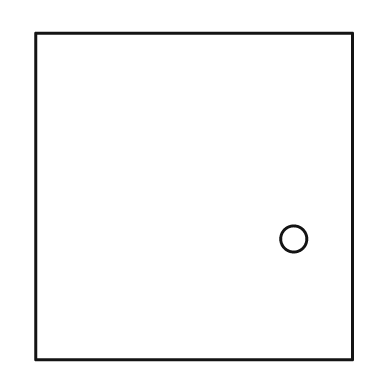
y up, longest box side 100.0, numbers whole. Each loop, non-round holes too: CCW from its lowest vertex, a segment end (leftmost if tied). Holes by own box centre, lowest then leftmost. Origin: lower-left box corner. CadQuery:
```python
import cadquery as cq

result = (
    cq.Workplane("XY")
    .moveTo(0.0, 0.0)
    .lineTo(97.0, 0.0)
    .lineTo(97.0, 100.0)
    .lineTo(0.0, 100.0)
    .close()
    .moveTo(79.0, 37.0)
    .circle(4.0)
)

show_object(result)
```